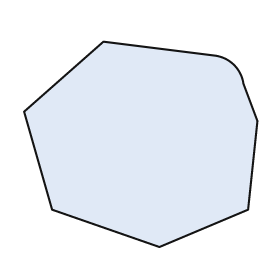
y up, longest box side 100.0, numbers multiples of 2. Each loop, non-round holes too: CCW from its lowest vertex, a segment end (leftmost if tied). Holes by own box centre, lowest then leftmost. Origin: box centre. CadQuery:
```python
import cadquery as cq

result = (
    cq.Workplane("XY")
    .moveTo(8.0, -44.0)
    .lineTo(46.0, -28.0)
    .lineTo(50.0, 10.0)
    .lineTo(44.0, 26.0)
    .threePointArc((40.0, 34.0), (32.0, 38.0))
    .lineTo(-16.0, 44.0)
    .lineTo(-50.0, 14.0)
    .lineTo(-38.0, -28.0)
    .close()
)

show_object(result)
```